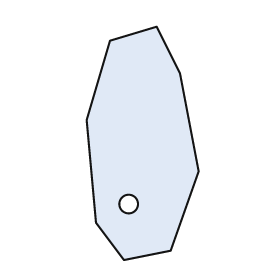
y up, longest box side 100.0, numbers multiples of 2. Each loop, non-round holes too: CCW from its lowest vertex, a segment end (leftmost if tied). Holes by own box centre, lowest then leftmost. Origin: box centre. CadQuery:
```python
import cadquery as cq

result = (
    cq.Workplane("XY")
    .moveTo(-8.0, -50.0)
    .lineTo(12.0, -46.0)
    .lineTo(24.0, -12.0)
    .lineTo(16.0, 30.0)
    .lineTo(6.0, 50.0)
    .lineTo(-14.0, 44.0)
    .lineTo(-24.0, 10.0)
    .lineTo(-20.0, -34.0)
    .close()
    .moveTo(-6.0, -26.0)
    .circle(4.0)
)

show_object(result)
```